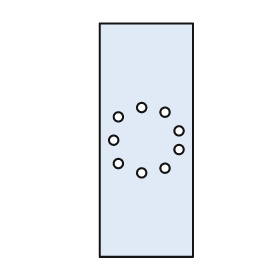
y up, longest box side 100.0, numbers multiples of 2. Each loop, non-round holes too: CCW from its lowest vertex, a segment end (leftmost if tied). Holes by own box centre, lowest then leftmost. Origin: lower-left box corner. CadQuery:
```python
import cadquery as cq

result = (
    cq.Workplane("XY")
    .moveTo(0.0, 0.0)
    .lineTo(40.0, 0.0)
    .lineTo(40.0, 100.0)
    .lineTo(0.0, 100.0)
    .close()
    .moveTo(18.0, 36.0)
    .circle(2.0)
    .moveTo(28.0, 38.0)
    .circle(2.0)
    .moveTo(8.0, 40.0)
    .circle(2.0)
    .moveTo(34.0, 46.0)
    .circle(2.0)
    .moveTo(6.0, 50.0)
    .circle(2.0)
    .moveTo(34.0, 54.0)
    .circle(2.0)
    .moveTo(8.0, 60.0)
    .circle(2.0)
    .moveTo(28.0, 62.0)
    .circle(2.0)
    .moveTo(18.0, 64.0)
    .circle(2.0)
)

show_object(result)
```